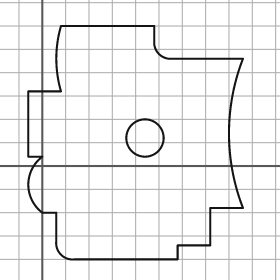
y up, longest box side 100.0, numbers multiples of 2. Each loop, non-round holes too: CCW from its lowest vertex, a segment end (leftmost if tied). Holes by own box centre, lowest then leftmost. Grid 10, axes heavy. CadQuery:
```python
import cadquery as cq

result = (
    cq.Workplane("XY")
    .moveTo(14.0, -40.0)
    .lineTo(58.0, -40.0)
    .lineTo(58.0, -34.0)
    .lineTo(72.0, -34.0)
    .lineTo(72.0, -18.0)
    .lineTo(86.0, -18.0)
    .threePointArc((80.0, 14.0), (86.0, 46.0))
    .lineTo(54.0, 46.0)
    .threePointArc((50.0, 48.0), (48.0, 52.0))
    .lineTo(48.0, 60.0)
    .lineTo(8.0, 60.0)
    .threePointArc((6.0, 46.0), (8.0, 32.0))
    .lineTo(-6.0, 32.0)
    .lineTo(-6.0, 4.0)
    .lineTo(0.0, 4.0)
    .threePointArc((-6.0, -8.0), (0.0, -20.0))
    .lineTo(6.0, -20.0)
    .lineTo(6.0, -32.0)
    .threePointArc((8.0, -38.0), (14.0, -40.0))
    .close()
    .moveTo(44.0, 12.0)
    .circle(8.0)
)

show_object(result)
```